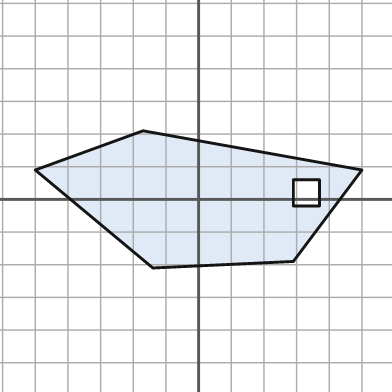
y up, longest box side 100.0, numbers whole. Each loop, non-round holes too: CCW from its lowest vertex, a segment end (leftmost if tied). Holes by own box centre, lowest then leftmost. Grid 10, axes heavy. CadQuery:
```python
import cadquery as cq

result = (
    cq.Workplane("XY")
    .moveTo(-14.0, -21.0)
    .lineTo(29.0, -19.0)
    .lineTo(50.0, 9.0)
    .lineTo(-17.0, 21.0)
    .lineTo(-50.0, 9.0)
    .close()
    .moveTo(29.0, -2.0)
    .lineTo(37.0, -2.0)
    .lineTo(37.0, 6.0)
    .lineTo(29.0, 6.0)
    .close()
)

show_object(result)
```